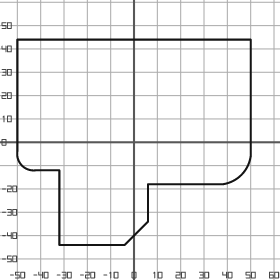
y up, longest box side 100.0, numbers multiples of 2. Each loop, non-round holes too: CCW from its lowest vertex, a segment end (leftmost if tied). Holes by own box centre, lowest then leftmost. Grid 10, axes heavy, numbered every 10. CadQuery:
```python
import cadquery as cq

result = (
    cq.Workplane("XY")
    .moveTo(-32.0, -44.0)
    .lineTo(-4.0, -44.0)
    .lineTo(6.0, -34.0)
    .lineTo(6.0, -18.0)
    .lineTo(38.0, -18.0)
    .threePointArc((46.0, -14.0), (50.0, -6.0))
    .lineTo(50.0, 44.0)
    .lineTo(-50.0, 44.0)
    .lineTo(-50.0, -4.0)
    .threePointArc((-48.0, -10.0), (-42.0, -12.0))
    .lineTo(-32.0, -12.0)
    .close()
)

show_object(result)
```